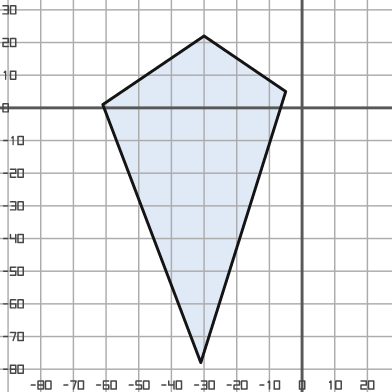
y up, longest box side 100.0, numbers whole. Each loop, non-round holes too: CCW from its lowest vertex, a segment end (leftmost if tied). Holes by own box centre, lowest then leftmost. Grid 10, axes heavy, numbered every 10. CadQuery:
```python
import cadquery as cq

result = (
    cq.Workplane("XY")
    .moveTo(-31.0, -78.0)
    .lineTo(-5.0, 5.0)
    .lineTo(-30.0, 22.0)
    .lineTo(-61.0, 1.0)
    .close()
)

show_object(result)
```